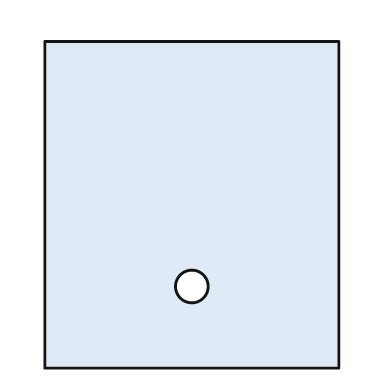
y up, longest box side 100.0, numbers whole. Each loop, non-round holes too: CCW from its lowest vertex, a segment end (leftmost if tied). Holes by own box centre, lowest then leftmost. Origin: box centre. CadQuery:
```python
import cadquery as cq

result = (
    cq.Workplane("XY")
    .moveTo(-45.0, -50.0)
    .lineTo(45.0, -50.0)
    .lineTo(45.0, 50.0)
    .lineTo(-45.0, 50.0)
    .close()
    .moveTo(0.0, -25.0)
    .circle(5.0)
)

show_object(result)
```